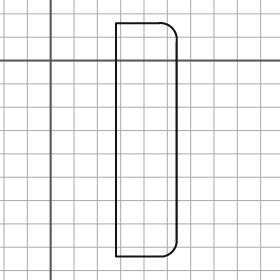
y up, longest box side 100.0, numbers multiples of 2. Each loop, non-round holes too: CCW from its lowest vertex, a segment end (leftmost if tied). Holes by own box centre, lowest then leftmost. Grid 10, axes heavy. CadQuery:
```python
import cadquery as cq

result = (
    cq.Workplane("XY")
    .moveTo(28.0, -84.0)
    .lineTo(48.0, -84.0)
    .threePointArc((52.0, -82.0), (54.0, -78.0))
    .lineTo(54.0, 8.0)
    .threePointArc((52.0, 14.0), (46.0, 16.0))
    .lineTo(28.0, 16.0)
    .close()
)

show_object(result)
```